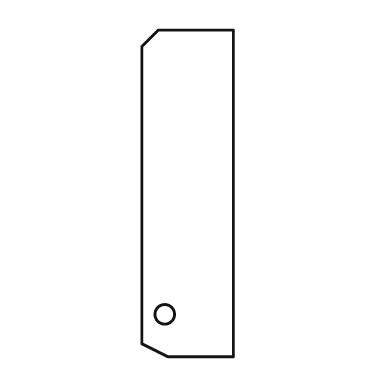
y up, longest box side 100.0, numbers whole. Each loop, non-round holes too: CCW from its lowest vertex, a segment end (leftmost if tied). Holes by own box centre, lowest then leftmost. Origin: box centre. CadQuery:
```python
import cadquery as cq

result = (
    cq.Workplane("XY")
    .moveTo(-6.0, -50.0)
    .lineTo(14.0, -50.0)
    .lineTo(14.0, 50.0)
    .lineTo(-9.0, 50.0)
    .lineTo(-14.0, 45.0)
    .lineTo(-14.0, -46.0)
    .close()
    .moveTo(-7.0, -37.0)
    .circle(3.0)
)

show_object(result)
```